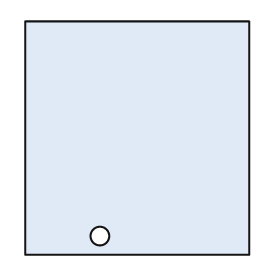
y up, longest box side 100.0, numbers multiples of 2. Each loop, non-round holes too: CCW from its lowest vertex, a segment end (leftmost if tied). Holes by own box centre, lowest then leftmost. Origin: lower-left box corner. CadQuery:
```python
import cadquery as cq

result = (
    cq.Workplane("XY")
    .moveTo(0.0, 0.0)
    .lineTo(96.0, 0.0)
    .lineTo(96.0, 100.0)
    .lineTo(0.0, 100.0)
    .close()
    .moveTo(32.0, 8.0)
    .circle(4.0)
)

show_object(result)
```